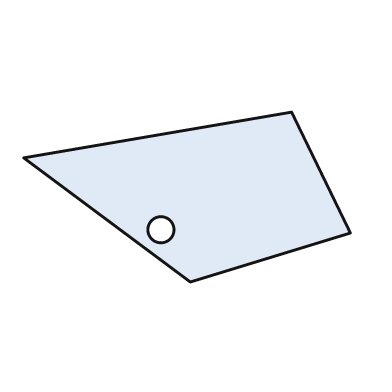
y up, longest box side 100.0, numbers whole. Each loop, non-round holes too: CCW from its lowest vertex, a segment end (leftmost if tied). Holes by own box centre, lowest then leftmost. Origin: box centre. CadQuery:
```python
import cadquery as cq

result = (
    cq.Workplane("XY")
    .moveTo(1.0, -26.0)
    .lineTo(50.0, -11.0)
    .lineTo(32.0, 26.0)
    .lineTo(-50.0, 12.0)
    .close()
    .moveTo(-8.0, -10.0)
    .circle(4.0)
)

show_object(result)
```